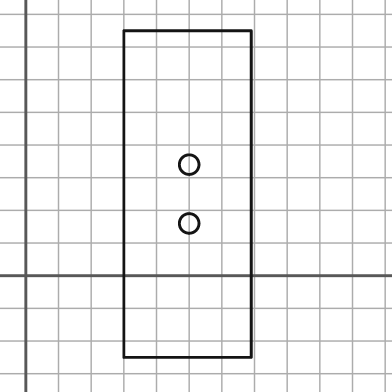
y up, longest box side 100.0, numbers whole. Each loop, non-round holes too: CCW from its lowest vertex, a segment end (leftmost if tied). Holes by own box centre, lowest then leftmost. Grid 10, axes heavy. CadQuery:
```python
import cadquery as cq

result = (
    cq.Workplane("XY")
    .moveTo(30.0, -25.0)
    .lineTo(69.0, -25.0)
    .lineTo(69.0, 75.0)
    .lineTo(30.0, 75.0)
    .close()
    .moveTo(50.0, 16.0)
    .circle(3.0)
    .moveTo(50.0, 34.0)
    .circle(3.0)
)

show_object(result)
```